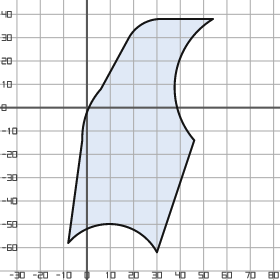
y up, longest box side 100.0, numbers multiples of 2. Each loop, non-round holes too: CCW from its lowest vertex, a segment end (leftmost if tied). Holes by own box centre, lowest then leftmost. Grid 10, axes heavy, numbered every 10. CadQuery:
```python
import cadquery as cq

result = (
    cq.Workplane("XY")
    .moveTo(30.0, -62.0)
    .lineTo(46.0, -14.0)
    .threePointArc((38.0, 14.0), (54.0, 38.0))
    .lineTo(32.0, 38.0)
    .threePointArc((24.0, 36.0), (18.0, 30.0))
    .lineTo(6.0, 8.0)
    .threePointArc((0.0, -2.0), (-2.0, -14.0))
    .lineTo(-8.0, -58.0)
    .threePointArc((12.0, -50.0), (30.0, -62.0))
    .close()
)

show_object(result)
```